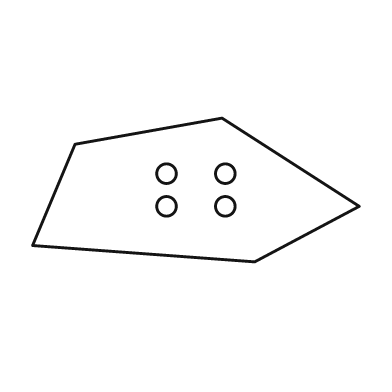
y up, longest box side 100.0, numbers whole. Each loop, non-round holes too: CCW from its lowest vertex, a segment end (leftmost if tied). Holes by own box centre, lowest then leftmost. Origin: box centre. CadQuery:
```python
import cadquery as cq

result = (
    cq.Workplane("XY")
    .moveTo(18.0, -22.0)
    .lineTo(50.0, -5.0)
    .lineTo(8.0, 22.0)
    .lineTo(-37.0, 14.0)
    .lineTo(-50.0, -17.0)
    .close()
    .moveTo(-9.0, -5.0)
    .circle(3.0)
    .moveTo(9.0, -5.0)
    .circle(3.0)
    .moveTo(-9.0, 5.0)
    .circle(3.0)
    .moveTo(9.0, 5.0)
    .circle(3.0)
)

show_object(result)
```